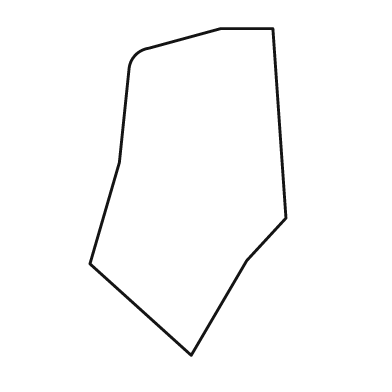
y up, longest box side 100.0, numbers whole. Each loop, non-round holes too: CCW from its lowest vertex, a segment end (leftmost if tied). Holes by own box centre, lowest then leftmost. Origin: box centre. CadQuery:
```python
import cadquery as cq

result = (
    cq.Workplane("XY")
    .moveTo(1.0, -50.0)
    .lineTo(18.0, -21.0)
    .lineTo(30.0, -8.0)
    .lineTo(26.0, 50.0)
    .lineTo(10.0, 50.0)
    .lineTo(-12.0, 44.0)
    .threePointArc((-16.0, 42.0), (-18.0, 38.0))
    .lineTo(-21.0, 9.0)
    .lineTo(-30.0, -22.0)
    .close()
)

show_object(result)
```